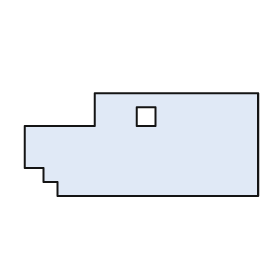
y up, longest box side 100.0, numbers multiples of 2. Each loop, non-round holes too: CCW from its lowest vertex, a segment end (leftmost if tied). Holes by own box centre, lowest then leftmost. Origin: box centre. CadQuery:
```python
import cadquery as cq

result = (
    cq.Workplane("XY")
    .moveTo(-36.0, -22.0)
    .lineTo(50.0, -22.0)
    .lineTo(50.0, 22.0)
    .lineTo(-20.0, 22.0)
    .lineTo(-20.0, 8.0)
    .lineTo(-50.0, 8.0)
    .lineTo(-50.0, -10.0)
    .lineTo(-42.0, -10.0)
    .lineTo(-42.0, -16.0)
    .lineTo(-36.0, -16.0)
    .close()
    .moveTo(-2.0, 8.0)
    .lineTo(6.0, 8.0)
    .lineTo(6.0, 16.0)
    .lineTo(-2.0, 16.0)
    .close()
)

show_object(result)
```